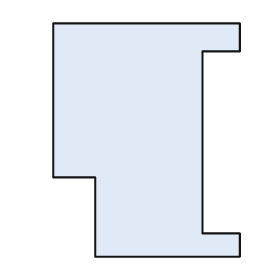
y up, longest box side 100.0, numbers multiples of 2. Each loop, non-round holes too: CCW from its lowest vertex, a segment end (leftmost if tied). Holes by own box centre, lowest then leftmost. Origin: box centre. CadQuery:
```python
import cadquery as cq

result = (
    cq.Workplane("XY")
    .moveTo(-22.0, -50.0)
    .lineTo(40.0, -50.0)
    .lineTo(40.0, -40.0)
    .lineTo(24.0, -40.0)
    .lineTo(24.0, 38.0)
    .lineTo(40.0, 38.0)
    .lineTo(40.0, 50.0)
    .lineTo(-40.0, 50.0)
    .lineTo(-40.0, -16.0)
    .lineTo(-22.0, -16.0)
    .close()
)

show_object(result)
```